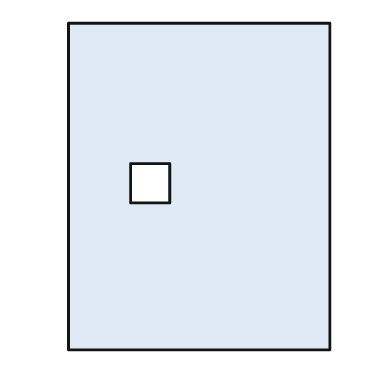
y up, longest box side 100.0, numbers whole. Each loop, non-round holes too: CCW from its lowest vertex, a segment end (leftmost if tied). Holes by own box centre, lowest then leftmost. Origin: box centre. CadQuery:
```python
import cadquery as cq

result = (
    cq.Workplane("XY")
    .moveTo(-40.0, -50.0)
    .lineTo(40.0, -50.0)
    .lineTo(40.0, 50.0)
    .lineTo(-40.0, 50.0)
    .close()
    .moveTo(-21.0, -5.0)
    .lineTo(-9.0, -5.0)
    .lineTo(-9.0, 7.0)
    .lineTo(-21.0, 7.0)
    .close()
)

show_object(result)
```